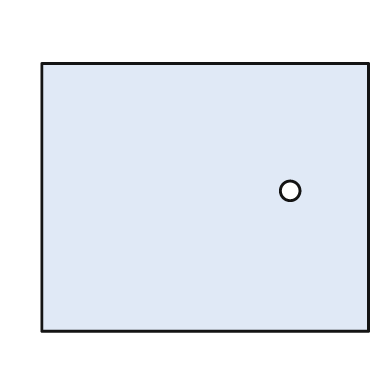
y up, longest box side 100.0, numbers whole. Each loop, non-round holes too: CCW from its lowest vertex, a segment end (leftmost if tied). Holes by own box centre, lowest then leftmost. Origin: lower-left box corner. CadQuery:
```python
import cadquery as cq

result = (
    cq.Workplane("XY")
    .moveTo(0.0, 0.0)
    .lineTo(100.0, 0.0)
    .lineTo(100.0, 82.0)
    .lineTo(0.0, 82.0)
    .close()
    .moveTo(76.0, 43.0)
    .circle(3.0)
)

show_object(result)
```